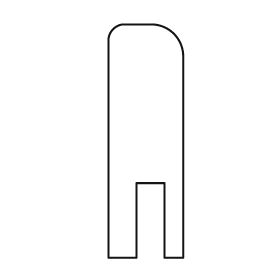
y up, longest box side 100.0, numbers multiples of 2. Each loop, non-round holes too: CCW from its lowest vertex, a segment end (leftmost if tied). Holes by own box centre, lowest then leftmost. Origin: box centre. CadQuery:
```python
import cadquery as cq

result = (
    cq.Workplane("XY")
    .moveTo(-16.0, -50.0)
    .lineTo(-4.0, -50.0)
    .lineTo(-4.0, -18.0)
    .lineTo(8.0, -18.0)
    .lineTo(8.0, -50.0)
    .lineTo(16.0, -50.0)
    .lineTo(16.0, 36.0)
    .threePointArc((12.0, 46.0), (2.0, 50.0))
    .lineTo(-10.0, 50.0)
    .threePointArc((-14.0, 48.0), (-16.0, 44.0))
    .close()
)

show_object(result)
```